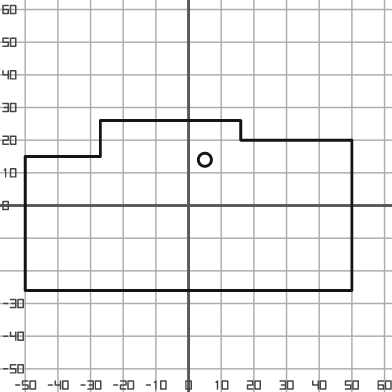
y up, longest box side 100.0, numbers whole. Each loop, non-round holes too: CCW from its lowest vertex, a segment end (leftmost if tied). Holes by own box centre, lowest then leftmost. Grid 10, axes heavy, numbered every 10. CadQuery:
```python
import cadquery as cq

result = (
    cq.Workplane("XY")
    .moveTo(-50.0, -26.0)
    .lineTo(50.0, -26.0)
    .lineTo(50.0, 20.0)
    .lineTo(16.0, 20.0)
    .lineTo(16.0, 26.0)
    .lineTo(-27.0, 26.0)
    .lineTo(-27.0, 15.0)
    .lineTo(-50.0, 15.0)
    .close()
    .moveTo(5.0, 14.0)
    .circle(2.0)
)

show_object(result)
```